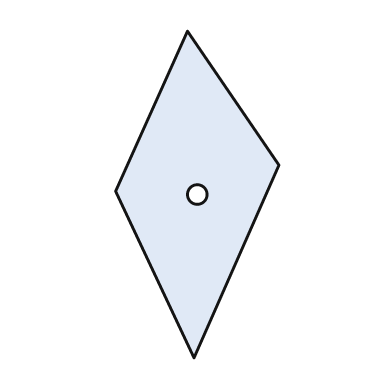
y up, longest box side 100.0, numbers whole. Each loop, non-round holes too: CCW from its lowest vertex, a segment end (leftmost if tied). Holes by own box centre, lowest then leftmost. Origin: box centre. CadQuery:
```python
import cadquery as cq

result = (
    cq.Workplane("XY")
    .moveTo(-1.0, -50.0)
    .lineTo(25.0, 9.0)
    .lineTo(-3.0, 50.0)
    .lineTo(-25.0, 1.0)
    .close()
    .moveTo(0.0, 0.0)
    .circle(3.0)
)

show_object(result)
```